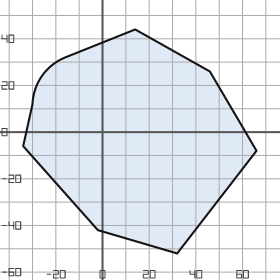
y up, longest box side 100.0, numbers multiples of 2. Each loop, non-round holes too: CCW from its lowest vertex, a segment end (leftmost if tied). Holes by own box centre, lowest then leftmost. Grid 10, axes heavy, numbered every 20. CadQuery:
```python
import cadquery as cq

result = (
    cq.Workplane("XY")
    .moveTo(32.0, -52.0)
    .lineTo(66.0, -8.0)
    .lineTo(46.0, 26.0)
    .lineTo(14.0, 44.0)
    .lineTo(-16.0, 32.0)
    .threePointArc((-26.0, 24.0), (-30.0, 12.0))
    .lineTo(-34.0, -6.0)
    .lineTo(-2.0, -42.0)
    .close()
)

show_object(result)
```